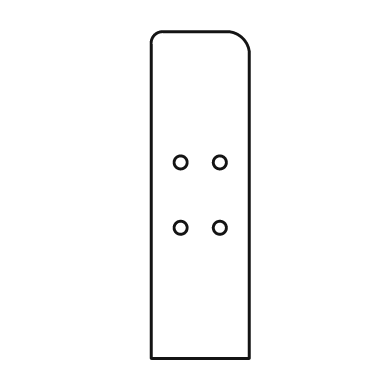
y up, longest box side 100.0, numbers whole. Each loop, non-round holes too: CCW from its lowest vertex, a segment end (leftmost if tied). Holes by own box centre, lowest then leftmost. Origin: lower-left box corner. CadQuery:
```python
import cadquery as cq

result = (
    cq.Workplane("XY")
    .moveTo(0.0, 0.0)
    .lineTo(30.0, 0.0)
    .lineTo(30.0, 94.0)
    .threePointArc((28.0, 98.0), (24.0, 100.0))
    .lineTo(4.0, 100.0)
    .threePointArc((1.0, 99.0), (0.0, 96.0))
    .close()
    .moveTo(9.0, 40.0)
    .circle(2.0)
    .moveTo(21.0, 40.0)
    .circle(2.0)
    .moveTo(9.0, 60.0)
    .circle(2.0)
    .moveTo(21.0, 60.0)
    .circle(2.0)
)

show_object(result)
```